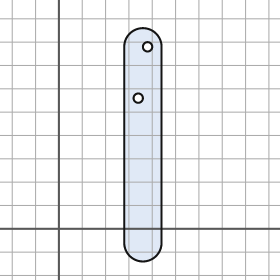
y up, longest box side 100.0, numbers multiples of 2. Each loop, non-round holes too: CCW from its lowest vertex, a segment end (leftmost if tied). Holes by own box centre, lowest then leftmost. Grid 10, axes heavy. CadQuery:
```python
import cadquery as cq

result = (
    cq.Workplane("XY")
    .moveTo(28.0, -6.0)
    .threePointArc((36.0, -14.0), (44.0, -6.0))
    .lineTo(44.0, 78.0)
    .threePointArc((36.0, 86.0), (28.0, 78.0))
    .close()
    .moveTo(34.0, 56.0)
    .circle(2.0)
    .moveTo(38.0, 78.0)
    .circle(2.0)
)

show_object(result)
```